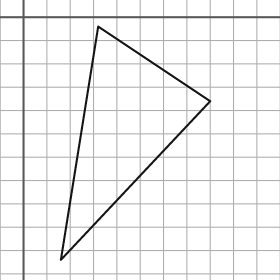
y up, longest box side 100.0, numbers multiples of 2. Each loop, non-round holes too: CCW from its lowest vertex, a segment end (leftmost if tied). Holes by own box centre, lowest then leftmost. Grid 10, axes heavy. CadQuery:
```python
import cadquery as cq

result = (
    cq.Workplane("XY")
    .moveTo(16.0, -104.0)
    .lineTo(80.0, -36.0)
    .lineTo(32.0, -4.0)
    .close()
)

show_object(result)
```